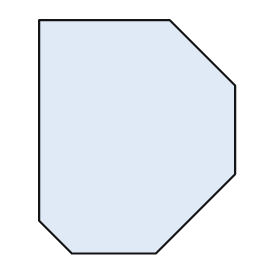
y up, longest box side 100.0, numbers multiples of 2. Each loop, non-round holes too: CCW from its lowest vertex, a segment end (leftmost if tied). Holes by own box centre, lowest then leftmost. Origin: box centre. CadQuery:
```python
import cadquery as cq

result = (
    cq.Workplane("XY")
    .moveTo(-28.0, -50.0)
    .lineTo(8.0, -50.0)
    .lineTo(42.0, -16.0)
    .lineTo(42.0, 22.0)
    .lineTo(14.0, 50.0)
    .lineTo(-42.0, 50.0)
    .lineTo(-42.0, -36.0)
    .close()
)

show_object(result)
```